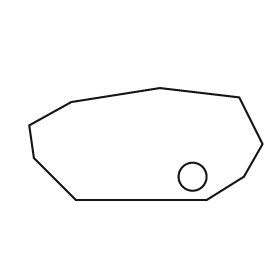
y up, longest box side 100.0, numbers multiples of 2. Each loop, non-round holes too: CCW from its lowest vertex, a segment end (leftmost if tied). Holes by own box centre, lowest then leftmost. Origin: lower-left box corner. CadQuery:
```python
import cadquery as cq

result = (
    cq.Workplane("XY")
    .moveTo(20.0, 0.0)
    .lineTo(76.0, 0.0)
    .lineTo(92.0, 10.0)
    .lineTo(100.0, 24.0)
    .lineTo(90.0, 44.0)
    .lineTo(56.0, 48.0)
    .lineTo(18.0, 42.0)
    .lineTo(0.0, 32.0)
    .lineTo(2.0, 18.0)
    .close()
    .moveTo(70.0, 10.0)
    .circle(6.0)
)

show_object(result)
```